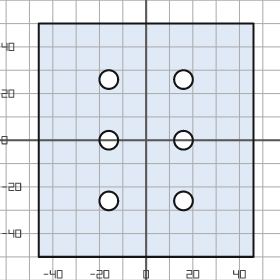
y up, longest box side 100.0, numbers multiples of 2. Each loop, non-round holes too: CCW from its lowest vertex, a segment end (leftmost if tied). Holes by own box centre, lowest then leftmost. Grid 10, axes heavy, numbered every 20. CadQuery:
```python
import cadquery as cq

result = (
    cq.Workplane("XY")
    .moveTo(-46.0, -50.0)
    .lineTo(46.0, -50.0)
    .lineTo(46.0, 50.0)
    .lineTo(-46.0, 50.0)
    .close()
    .moveTo(-16.0, -26.0)
    .circle(4.0)
    .moveTo(16.0, -26.0)
    .circle(4.0)
    .moveTo(-16.0, 0.0)
    .circle(4.0)
    .moveTo(16.0, 0.0)
    .circle(4.0)
    .moveTo(-16.0, 26.0)
    .circle(4.0)
    .moveTo(16.0, 26.0)
    .circle(4.0)
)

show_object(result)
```